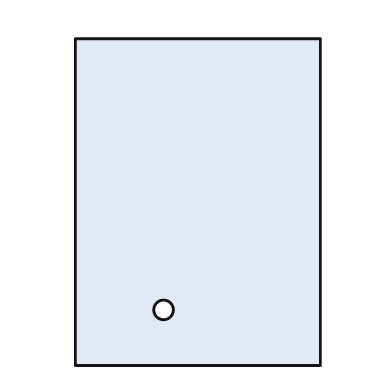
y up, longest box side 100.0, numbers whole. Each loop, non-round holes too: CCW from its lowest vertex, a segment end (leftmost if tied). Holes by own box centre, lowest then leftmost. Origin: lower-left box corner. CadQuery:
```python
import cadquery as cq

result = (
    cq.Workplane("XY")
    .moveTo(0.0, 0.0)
    .lineTo(75.0, 0.0)
    .lineTo(75.0, 100.0)
    .lineTo(0.0, 100.0)
    .close()
    .moveTo(27.0, 17.0)
    .circle(3.0)
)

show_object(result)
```